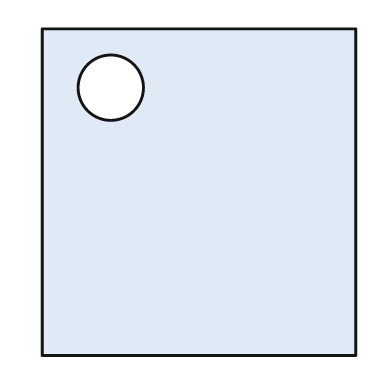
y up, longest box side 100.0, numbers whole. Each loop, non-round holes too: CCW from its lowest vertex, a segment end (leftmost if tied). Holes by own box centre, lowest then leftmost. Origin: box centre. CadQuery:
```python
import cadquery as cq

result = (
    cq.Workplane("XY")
    .moveTo(-48.0, -50.0)
    .lineTo(48.0, -50.0)
    .lineTo(48.0, 50.0)
    .lineTo(-48.0, 50.0)
    .close()
    .moveTo(-27.0, 32.0)
    .circle(10.0)
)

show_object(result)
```